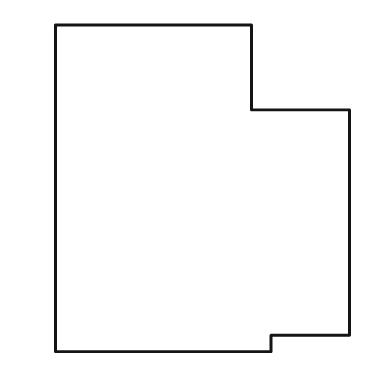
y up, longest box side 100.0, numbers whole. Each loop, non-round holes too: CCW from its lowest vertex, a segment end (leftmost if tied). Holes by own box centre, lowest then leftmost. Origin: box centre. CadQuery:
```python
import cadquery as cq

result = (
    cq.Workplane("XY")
    .moveTo(-45.0, -50.0)
    .lineTo(21.0, -50.0)
    .lineTo(21.0, -45.0)
    .lineTo(45.0, -45.0)
    .lineTo(45.0, 24.0)
    .lineTo(15.0, 24.0)
    .lineTo(15.0, 50.0)
    .lineTo(-45.0, 50.0)
    .close()
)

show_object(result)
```